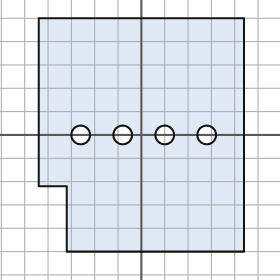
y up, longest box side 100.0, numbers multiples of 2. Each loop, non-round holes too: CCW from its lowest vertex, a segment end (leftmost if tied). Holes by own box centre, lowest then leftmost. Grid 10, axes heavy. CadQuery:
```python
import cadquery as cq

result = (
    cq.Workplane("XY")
    .moveTo(-32.0, -50.0)
    .lineTo(44.0, -50.0)
    .lineTo(44.0, 50.0)
    .lineTo(-44.0, 50.0)
    .lineTo(-44.0, -22.0)
    .lineTo(-32.0, -22.0)
    .close()
    .moveTo(-26.0, 0.0)
    .circle(4.0)
    .moveTo(-8.0, 0.0)
    .circle(4.0)
    .moveTo(10.0, 0.0)
    .circle(4.0)
    .moveTo(28.0, 0.0)
    .circle(4.0)
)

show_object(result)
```